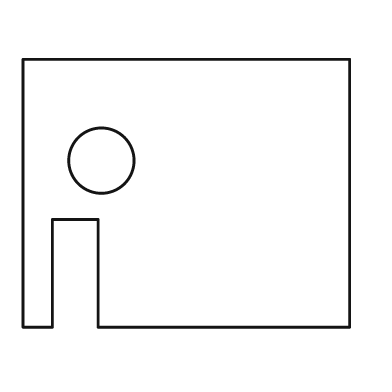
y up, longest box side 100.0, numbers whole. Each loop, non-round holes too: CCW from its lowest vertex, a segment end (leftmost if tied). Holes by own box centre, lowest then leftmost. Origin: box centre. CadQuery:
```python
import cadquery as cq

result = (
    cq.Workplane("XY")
    .moveTo(-50.0, -41.0)
    .lineTo(-41.0, -41.0)
    .lineTo(-41.0, -8.0)
    .lineTo(-27.0, -8.0)
    .lineTo(-27.0, -41.0)
    .lineTo(50.0, -41.0)
    .lineTo(50.0, 41.0)
    .lineTo(-50.0, 41.0)
    .close()
    .moveTo(-26.0, 10.0)
    .circle(10.0)
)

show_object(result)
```